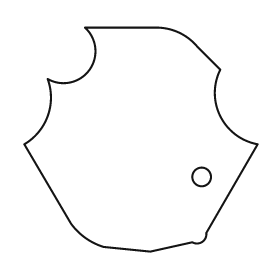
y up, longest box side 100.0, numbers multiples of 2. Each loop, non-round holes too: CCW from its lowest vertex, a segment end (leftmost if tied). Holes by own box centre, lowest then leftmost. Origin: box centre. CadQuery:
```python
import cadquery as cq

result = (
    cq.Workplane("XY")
    .moveTo(4.0, -48.0)
    .lineTo(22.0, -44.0)
    .threePointArc((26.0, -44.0), (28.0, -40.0))
    .lineTo(50.0, -2.0)
    .threePointArc((34.0, 10.0), (34.0, 30.0))
    .lineTo(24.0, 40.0)
    .threePointArc((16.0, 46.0), (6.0, 48.0))
    .lineTo(-24.0, 48.0)
    .threePointArc((-22.0, 30.0), (-40.0, 26.0))
    .threePointArc((-40.0, 10.0), (-50.0, -2.0))
    .lineTo(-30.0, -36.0)
    .threePointArc((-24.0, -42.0), (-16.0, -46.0))
    .close()
    .moveTo(26.0, -16.0)
    .circle(4.0)
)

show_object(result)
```